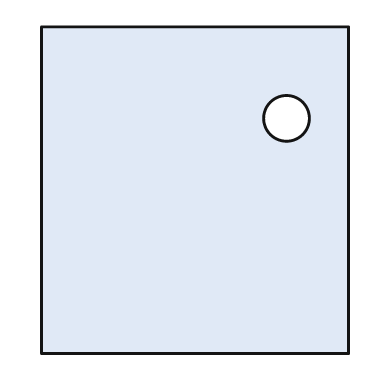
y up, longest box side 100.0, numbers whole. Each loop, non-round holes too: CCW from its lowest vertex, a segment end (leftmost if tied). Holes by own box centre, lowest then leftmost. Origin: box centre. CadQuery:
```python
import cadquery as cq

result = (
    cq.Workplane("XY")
    .moveTo(-47.0, -50.0)
    .lineTo(47.0, -50.0)
    .lineTo(47.0, 50.0)
    .lineTo(-47.0, 50.0)
    .close()
    .moveTo(28.0, 22.0)
    .circle(7.0)
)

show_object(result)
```